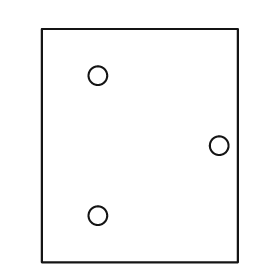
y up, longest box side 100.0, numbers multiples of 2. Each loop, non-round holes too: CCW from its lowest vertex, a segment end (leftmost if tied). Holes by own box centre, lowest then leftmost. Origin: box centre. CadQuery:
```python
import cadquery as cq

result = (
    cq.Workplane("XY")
    .moveTo(-42.0, -50.0)
    .lineTo(42.0, -50.0)
    .lineTo(42.0, 50.0)
    .lineTo(-42.0, 50.0)
    .close()
    .moveTo(-18.0, -30.0)
    .circle(4.0)
    .moveTo(34.0, 0.0)
    .circle(4.0)
    .moveTo(-18.0, 30.0)
    .circle(4.0)
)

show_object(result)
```